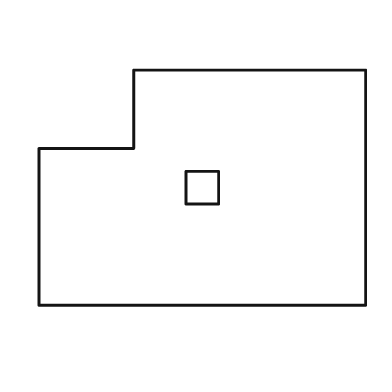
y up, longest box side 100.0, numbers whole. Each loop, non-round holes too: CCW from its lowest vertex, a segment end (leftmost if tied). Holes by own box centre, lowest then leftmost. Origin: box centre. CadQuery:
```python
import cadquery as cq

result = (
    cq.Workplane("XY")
    .moveTo(-50.0, -36.0)
    .lineTo(50.0, -36.0)
    .lineTo(50.0, 36.0)
    .lineTo(-21.0, 36.0)
    .lineTo(-21.0, 12.0)
    .lineTo(-50.0, 12.0)
    .close()
    .moveTo(-5.0, -5.0)
    .lineTo(5.0, -5.0)
    .lineTo(5.0, 5.0)
    .lineTo(-5.0, 5.0)
    .close()
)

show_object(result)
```